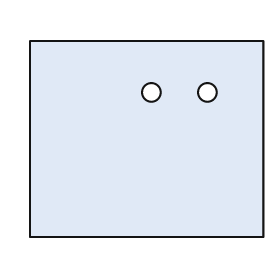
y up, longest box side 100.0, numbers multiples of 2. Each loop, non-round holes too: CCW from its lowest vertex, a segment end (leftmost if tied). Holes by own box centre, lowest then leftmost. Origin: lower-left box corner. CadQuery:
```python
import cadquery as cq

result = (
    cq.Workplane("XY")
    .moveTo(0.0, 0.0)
    .lineTo(100.0, 0.0)
    .lineTo(100.0, 84.0)
    .lineTo(0.0, 84.0)
    .close()
    .moveTo(52.0, 62.0)
    .circle(4.0)
    .moveTo(76.0, 62.0)
    .circle(4.0)
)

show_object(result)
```